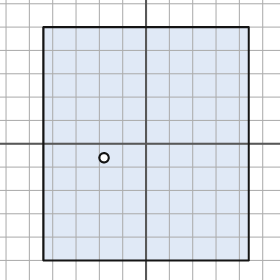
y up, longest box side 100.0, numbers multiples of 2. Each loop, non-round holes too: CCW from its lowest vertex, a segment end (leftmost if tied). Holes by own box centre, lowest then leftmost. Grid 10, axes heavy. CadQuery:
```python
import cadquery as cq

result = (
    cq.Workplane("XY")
    .moveTo(-44.0, -50.0)
    .lineTo(44.0, -50.0)
    .lineTo(44.0, 50.0)
    .lineTo(-44.0, 50.0)
    .close()
    .moveTo(-18.0, -6.0)
    .circle(2.0)
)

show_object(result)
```